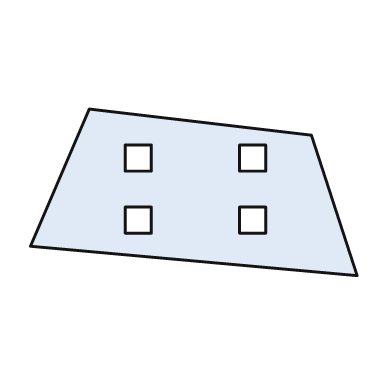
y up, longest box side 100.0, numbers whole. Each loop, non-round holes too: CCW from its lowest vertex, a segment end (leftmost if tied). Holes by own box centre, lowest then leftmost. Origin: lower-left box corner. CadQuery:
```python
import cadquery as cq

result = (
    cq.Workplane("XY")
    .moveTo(100.0, 0.0)
    .lineTo(86.0, 43.0)
    .lineTo(18.0, 51.0)
    .lineTo(0.0, 9.0)
    .close()
    .moveTo(29.0, 13.0)
    .lineTo(37.0, 13.0)
    .lineTo(37.0, 21.0)
    .lineTo(29.0, 21.0)
    .close()
    .moveTo(64.0, 13.0)
    .lineTo(72.0, 13.0)
    .lineTo(72.0, 21.0)
    .lineTo(64.0, 21.0)
    .close()
    .moveTo(29.0, 32.0)
    .lineTo(37.0, 32.0)
    .lineTo(37.0, 40.0)
    .lineTo(29.0, 40.0)
    .close()
    .moveTo(64.0, 32.0)
    .lineTo(72.0, 32.0)
    .lineTo(72.0, 40.0)
    .lineTo(64.0, 40.0)
    .close()
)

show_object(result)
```